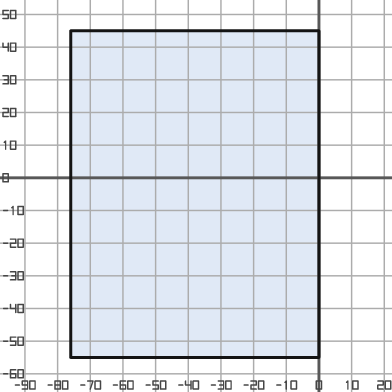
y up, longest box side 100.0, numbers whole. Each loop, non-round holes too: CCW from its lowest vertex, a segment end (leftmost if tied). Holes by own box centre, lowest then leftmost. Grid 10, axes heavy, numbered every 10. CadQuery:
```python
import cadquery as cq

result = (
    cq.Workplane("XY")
    .moveTo(-76.0, -55.0)
    .lineTo(0.0, -55.0)
    .lineTo(0.0, 45.0)
    .lineTo(-76.0, 45.0)
    .close()
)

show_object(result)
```